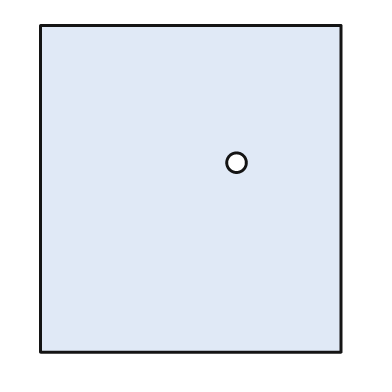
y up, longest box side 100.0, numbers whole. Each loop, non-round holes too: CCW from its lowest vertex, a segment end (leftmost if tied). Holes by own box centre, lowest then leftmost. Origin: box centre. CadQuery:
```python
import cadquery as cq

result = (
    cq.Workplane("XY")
    .moveTo(-46.0, -50.0)
    .lineTo(46.0, -50.0)
    .lineTo(46.0, 50.0)
    .lineTo(-46.0, 50.0)
    .close()
    .moveTo(14.0, 8.0)
    .circle(3.0)
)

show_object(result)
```